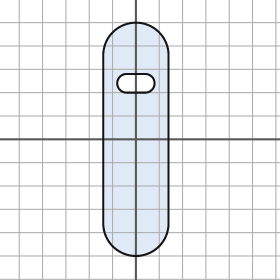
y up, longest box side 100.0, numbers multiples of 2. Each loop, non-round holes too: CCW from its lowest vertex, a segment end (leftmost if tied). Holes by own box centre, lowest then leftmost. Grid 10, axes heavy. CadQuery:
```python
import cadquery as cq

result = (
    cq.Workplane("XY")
    .moveTo(-14.0, -36.0)
    .threePointArc((0.0, -50.0), (14.0, -36.0))
    .lineTo(14.0, 36.0)
    .threePointArc((0.0, 50.0), (-14.0, 36.0))
    .close()
    .moveTo(-4.0, 20.0)
    .lineTo(4.0, 20.0)
    .threePointArc((8.0, 24.0), (4.0, 28.0))
    .lineTo(-4.0, 28.0)
    .threePointArc((-8.0, 24.0), (-4.0, 20.0))
    .close()
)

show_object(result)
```